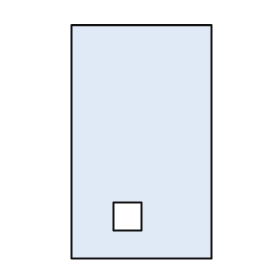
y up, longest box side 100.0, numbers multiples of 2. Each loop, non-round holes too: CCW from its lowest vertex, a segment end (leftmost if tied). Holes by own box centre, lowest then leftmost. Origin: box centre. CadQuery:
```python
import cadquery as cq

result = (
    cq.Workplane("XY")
    .moveTo(-30.0, -50.0)
    .lineTo(30.0, -50.0)
    .lineTo(30.0, 50.0)
    .lineTo(-30.0, 50.0)
    .close()
    .moveTo(-12.0, -38.0)
    .lineTo(0.0, -38.0)
    .lineTo(0.0, -26.0)
    .lineTo(-12.0, -26.0)
    .close()
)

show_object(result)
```